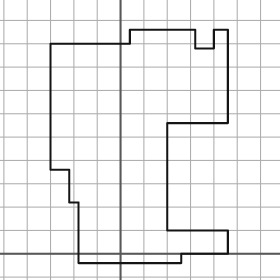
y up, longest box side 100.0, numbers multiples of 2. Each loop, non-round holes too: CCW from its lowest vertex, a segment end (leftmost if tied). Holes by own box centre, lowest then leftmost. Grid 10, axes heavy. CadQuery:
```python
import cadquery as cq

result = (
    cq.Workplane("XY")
    .moveTo(-18.0, -4.0)
    .lineTo(26.0, -4.0)
    .lineTo(26.0, 0.0)
    .lineTo(46.0, 0.0)
    .lineTo(46.0, 10.0)
    .lineTo(20.0, 10.0)
    .lineTo(20.0, 56.0)
    .lineTo(46.0, 56.0)
    .lineTo(46.0, 96.0)
    .lineTo(40.0, 96.0)
    .lineTo(40.0, 88.0)
    .lineTo(32.0, 88.0)
    .lineTo(32.0, 96.0)
    .lineTo(4.0, 96.0)
    .lineTo(4.0, 90.0)
    .lineTo(-30.0, 90.0)
    .lineTo(-30.0, 36.0)
    .lineTo(-22.0, 36.0)
    .lineTo(-22.0, 22.0)
    .lineTo(-18.0, 22.0)
    .close()
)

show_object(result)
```